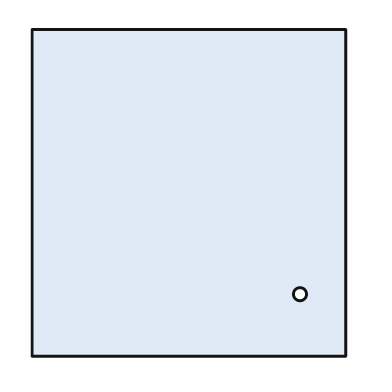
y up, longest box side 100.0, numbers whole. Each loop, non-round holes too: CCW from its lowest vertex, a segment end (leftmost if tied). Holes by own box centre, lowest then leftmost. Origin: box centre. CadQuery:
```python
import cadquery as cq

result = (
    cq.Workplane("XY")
    .moveTo(-48.0, -50.0)
    .lineTo(48.0, -50.0)
    .lineTo(48.0, 50.0)
    .lineTo(-48.0, 50.0)
    .close()
    .moveTo(34.0, -31.0)
    .circle(2.0)
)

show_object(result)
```